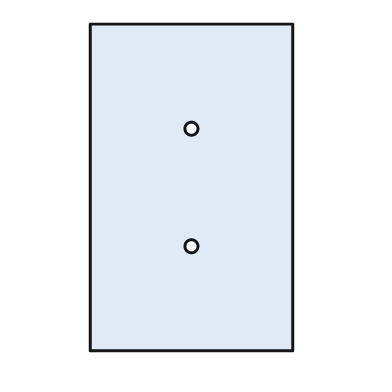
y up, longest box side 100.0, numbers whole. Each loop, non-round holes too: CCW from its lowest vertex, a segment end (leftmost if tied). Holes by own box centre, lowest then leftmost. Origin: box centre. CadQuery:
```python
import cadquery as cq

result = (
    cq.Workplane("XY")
    .moveTo(-31.0, -50.0)
    .lineTo(31.0, -50.0)
    .lineTo(31.0, 50.0)
    .lineTo(-31.0, 50.0)
    .close()
    .moveTo(0.0, -18.0)
    .circle(2.0)
    .moveTo(0.0, 18.0)
    .circle(2.0)
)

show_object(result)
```